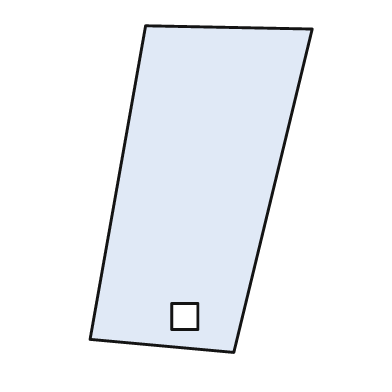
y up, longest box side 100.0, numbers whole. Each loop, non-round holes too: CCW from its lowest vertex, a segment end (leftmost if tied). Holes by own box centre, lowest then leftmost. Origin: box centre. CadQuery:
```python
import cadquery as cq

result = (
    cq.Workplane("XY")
    .moveTo(10.0, -50.0)
    .lineTo(34.0, 49.0)
    .lineTo(-17.0, 50.0)
    .lineTo(-34.0, -46.0)
    .close()
    .moveTo(-9.0, -43.0)
    .lineTo(-1.0, -43.0)
    .lineTo(-1.0, -35.0)
    .lineTo(-9.0, -35.0)
    .close()
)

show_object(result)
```